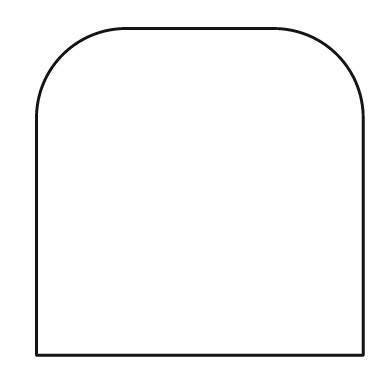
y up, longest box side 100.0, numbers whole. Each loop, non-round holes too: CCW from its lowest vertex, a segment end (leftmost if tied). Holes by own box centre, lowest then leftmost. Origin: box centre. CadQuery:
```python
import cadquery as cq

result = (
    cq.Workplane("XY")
    .moveTo(-50.0, -50.0)
    .lineTo(50.0, -50.0)
    .lineTo(50.0, 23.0)
    .threePointArc((42.0, 42.0), (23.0, 50.0))
    .lineTo(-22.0, 50.0)
    .threePointArc((-42.0, 42.0), (-50.0, 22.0))
    .close()
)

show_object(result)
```